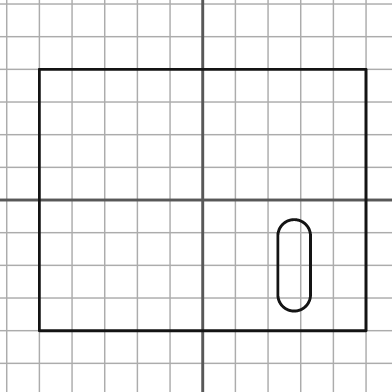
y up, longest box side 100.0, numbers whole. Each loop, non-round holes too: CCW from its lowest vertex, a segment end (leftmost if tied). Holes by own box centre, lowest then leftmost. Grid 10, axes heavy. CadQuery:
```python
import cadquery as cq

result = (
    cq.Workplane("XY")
    .moveTo(-50.0, -40.0)
    .lineTo(50.0, -40.0)
    .lineTo(50.0, 40.0)
    .lineTo(-50.0, 40.0)
    .close()
    .moveTo(23.0, -29.0)
    .threePointArc((28.0, -34.0), (33.0, -29.0))
    .lineTo(33.0, -11.0)
    .threePointArc((28.0, -6.0), (23.0, -11.0))
    .close()
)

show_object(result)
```